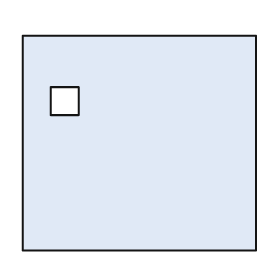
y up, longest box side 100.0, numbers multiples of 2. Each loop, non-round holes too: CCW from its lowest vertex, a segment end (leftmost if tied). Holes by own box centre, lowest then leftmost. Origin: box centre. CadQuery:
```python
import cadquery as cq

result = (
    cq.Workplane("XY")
    .moveTo(-50.0, -46.0)
    .lineTo(50.0, -46.0)
    .lineTo(50.0, 46.0)
    .lineTo(-50.0, 46.0)
    .close()
    .moveTo(-38.0, 12.0)
    .lineTo(-26.0, 12.0)
    .lineTo(-26.0, 24.0)
    .lineTo(-38.0, 24.0)
    .close()
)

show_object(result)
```